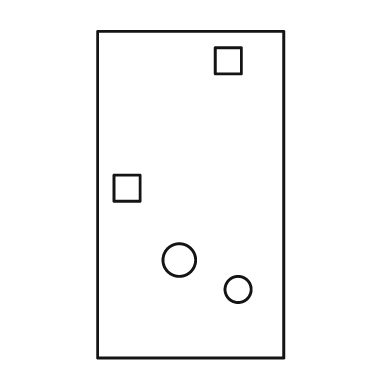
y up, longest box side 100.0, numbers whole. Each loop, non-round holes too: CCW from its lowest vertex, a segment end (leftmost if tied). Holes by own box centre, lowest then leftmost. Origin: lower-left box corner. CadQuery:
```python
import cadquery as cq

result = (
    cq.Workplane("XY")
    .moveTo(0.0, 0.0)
    .lineTo(57.0, 0.0)
    .lineTo(57.0, 100.0)
    .lineTo(0.0, 100.0)
    .close()
    .moveTo(43.0, 21.0)
    .circle(4.0)
    .moveTo(25.0, 30.0)
    .circle(5.0)
    .moveTo(5.0, 48.0)
    .lineTo(13.0, 48.0)
    .lineTo(13.0, 56.0)
    .lineTo(5.0, 56.0)
    .close()
    .moveTo(36.0, 87.0)
    .lineTo(44.0, 87.0)
    .lineTo(44.0, 95.0)
    .lineTo(36.0, 95.0)
    .close()
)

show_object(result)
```